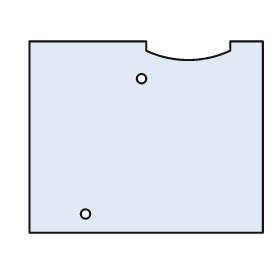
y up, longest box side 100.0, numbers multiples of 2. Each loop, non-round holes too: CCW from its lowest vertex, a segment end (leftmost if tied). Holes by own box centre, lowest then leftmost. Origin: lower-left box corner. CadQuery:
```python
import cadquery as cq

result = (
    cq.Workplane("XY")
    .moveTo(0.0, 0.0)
    .lineTo(100.0, 0.0)
    .lineTo(100.0, 82.0)
    .lineTo(86.0, 82.0)
    .lineTo(86.0, 78.0)
    .threePointArc((68.0, 74.0), (50.0, 78.0))
    .lineTo(50.0, 82.0)
    .lineTo(0.0, 82.0)
    .close()
    .moveTo(24.0, 8.0)
    .circle(2.0)
    .moveTo(48.0, 66.0)
    .circle(2.0)
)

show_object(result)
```